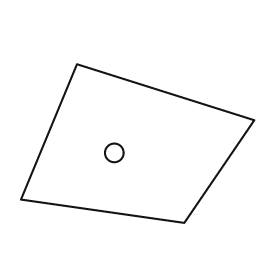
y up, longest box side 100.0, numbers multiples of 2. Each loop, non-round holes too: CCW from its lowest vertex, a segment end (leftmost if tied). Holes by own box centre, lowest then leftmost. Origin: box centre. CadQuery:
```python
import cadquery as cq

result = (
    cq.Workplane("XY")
    .moveTo(20.0, -34.0)
    .lineTo(50.0, 10.0)
    .lineTo(-26.0, 34.0)
    .lineTo(-50.0, -24.0)
    .close()
    .moveTo(-10.0, -4.0)
    .circle(4.0)
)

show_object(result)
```